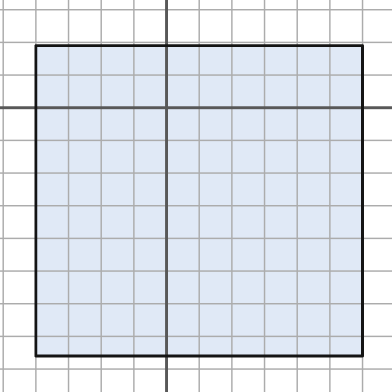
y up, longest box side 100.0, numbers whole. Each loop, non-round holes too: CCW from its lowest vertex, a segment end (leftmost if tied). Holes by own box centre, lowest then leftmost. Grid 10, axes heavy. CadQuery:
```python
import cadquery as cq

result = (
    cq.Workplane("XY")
    .moveTo(-40.0, -76.0)
    .lineTo(60.0, -76.0)
    .lineTo(60.0, 19.0)
    .lineTo(-40.0, 19.0)
    .close()
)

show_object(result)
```